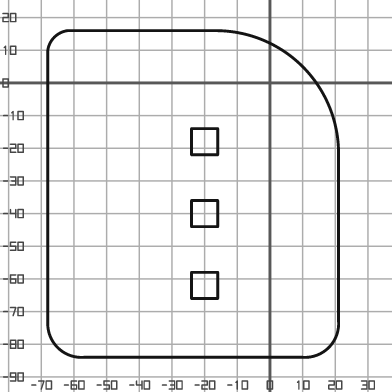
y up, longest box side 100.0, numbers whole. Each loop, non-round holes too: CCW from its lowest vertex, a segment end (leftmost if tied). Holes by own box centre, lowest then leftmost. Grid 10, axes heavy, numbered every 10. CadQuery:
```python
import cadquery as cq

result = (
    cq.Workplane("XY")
    .moveTo(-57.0, -84.0)
    .lineTo(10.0, -84.0)
    .threePointArc((18.0, -81.0), (21.0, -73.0))
    .lineTo(21.0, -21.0)
    .threePointArc((10.0, 5.0), (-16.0, 16.0))
    .lineTo(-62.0, 16.0)
    .threePointArc((-66.0, 14.0), (-68.0, 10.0))
    .lineTo(-68.0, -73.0)
    .threePointArc((-65.0, -81.0), (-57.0, -84.0))
    .close()
    .moveTo(-24.0, -66.0)
    .lineTo(-16.0, -66.0)
    .lineTo(-16.0, -58.0)
    .lineTo(-24.0, -58.0)
    .close()
    .moveTo(-24.0, -44.0)
    .lineTo(-16.0, -44.0)
    .lineTo(-16.0, -36.0)
    .lineTo(-24.0, -36.0)
    .close()
    .moveTo(-24.0, -22.0)
    .lineTo(-16.0, -22.0)
    .lineTo(-16.0, -14.0)
    .lineTo(-24.0, -14.0)
    .close()
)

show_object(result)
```